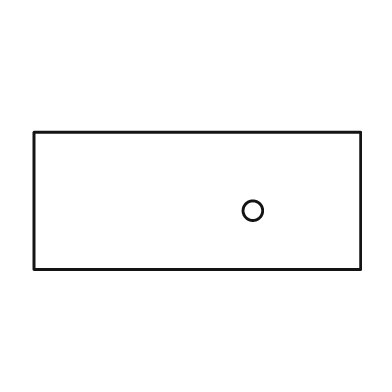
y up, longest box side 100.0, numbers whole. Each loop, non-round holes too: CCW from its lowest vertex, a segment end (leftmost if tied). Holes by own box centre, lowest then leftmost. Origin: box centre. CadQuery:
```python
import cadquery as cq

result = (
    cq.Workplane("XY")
    .moveTo(-50.0, -21.0)
    .lineTo(50.0, -21.0)
    .lineTo(50.0, 21.0)
    .lineTo(-50.0, 21.0)
    .close()
    .moveTo(17.0, -3.0)
    .circle(3.0)
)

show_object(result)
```